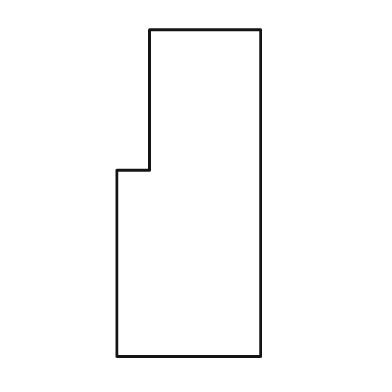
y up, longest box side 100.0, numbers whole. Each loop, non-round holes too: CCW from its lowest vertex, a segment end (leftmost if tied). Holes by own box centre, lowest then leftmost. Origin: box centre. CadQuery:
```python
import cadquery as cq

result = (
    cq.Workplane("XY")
    .moveTo(-22.0, -50.0)
    .lineTo(22.0, -50.0)
    .lineTo(22.0, 50.0)
    .lineTo(-12.0, 50.0)
    .lineTo(-12.0, 7.0)
    .lineTo(-22.0, 7.0)
    .close()
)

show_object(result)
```